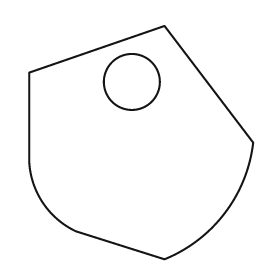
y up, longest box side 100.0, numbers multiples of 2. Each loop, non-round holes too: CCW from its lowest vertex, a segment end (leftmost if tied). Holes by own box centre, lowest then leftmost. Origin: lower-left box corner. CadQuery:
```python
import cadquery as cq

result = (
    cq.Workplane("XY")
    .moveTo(58.0, 0.0)
    .threePointArc((84.0, 20.0), (96.0, 50.0))
    .lineTo(58.0, 100.0)
    .lineTo(0.0, 80.0)
    .lineTo(0.0, 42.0)
    .threePointArc((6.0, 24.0), (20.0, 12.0))
    .close()
    .moveTo(44.0, 76.0)
    .circle(12.0)
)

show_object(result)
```